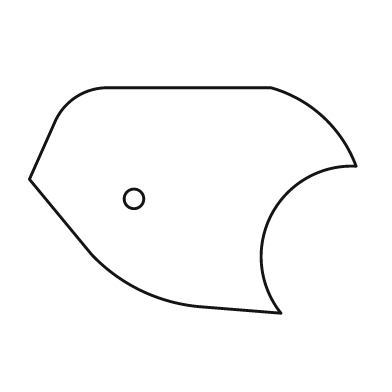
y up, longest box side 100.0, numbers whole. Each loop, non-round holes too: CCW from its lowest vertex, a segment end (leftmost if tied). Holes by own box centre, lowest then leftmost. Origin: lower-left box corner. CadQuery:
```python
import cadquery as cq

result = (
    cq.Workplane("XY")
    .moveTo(77.0, 0.0)
    .threePointArc((74.0, 30.0), (100.0, 45.0))
    .threePointArc((90.0, 60.0), (74.0, 69.0))
    .lineTo(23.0, 69.0)
    .threePointArc((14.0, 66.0), (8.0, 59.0))
    .lineTo(0.0, 41.0)
    .lineTo(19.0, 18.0)
    .threePointArc((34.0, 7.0), (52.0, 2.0))
    .close()
    .moveTo(32.0, 35.0)
    .circle(3.0)
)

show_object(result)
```